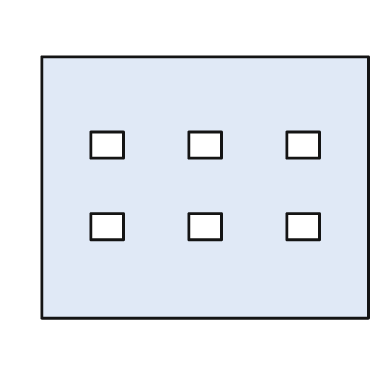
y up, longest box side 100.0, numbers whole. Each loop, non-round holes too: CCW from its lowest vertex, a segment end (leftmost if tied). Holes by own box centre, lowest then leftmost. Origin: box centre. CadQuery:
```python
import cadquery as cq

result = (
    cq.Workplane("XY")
    .moveTo(-50.0, -40.0)
    .lineTo(50.0, -40.0)
    .lineTo(50.0, 40.0)
    .lineTo(-50.0, 40.0)
    .close()
    .moveTo(-35.0, -16.0)
    .lineTo(-25.0, -16.0)
    .lineTo(-25.0, -8.0)
    .lineTo(-35.0, -8.0)
    .close()
    .moveTo(-5.0, -16.0)
    .lineTo(5.0, -16.0)
    .lineTo(5.0, -8.0)
    .lineTo(-5.0, -8.0)
    .close()
    .moveTo(25.0, -16.0)
    .lineTo(35.0, -16.0)
    .lineTo(35.0, -8.0)
    .lineTo(25.0, -8.0)
    .close()
    .moveTo(-35.0, 9.0)
    .lineTo(-25.0, 9.0)
    .lineTo(-25.0, 17.0)
    .lineTo(-35.0, 17.0)
    .close()
    .moveTo(-5.0, 9.0)
    .lineTo(5.0, 9.0)
    .lineTo(5.0, 17.0)
    .lineTo(-5.0, 17.0)
    .close()
    .moveTo(25.0, 9.0)
    .lineTo(35.0, 9.0)
    .lineTo(35.0, 17.0)
    .lineTo(25.0, 17.0)
    .close()
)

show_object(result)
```